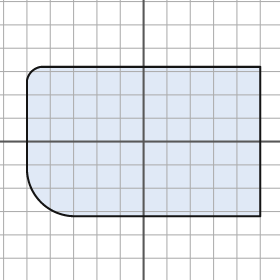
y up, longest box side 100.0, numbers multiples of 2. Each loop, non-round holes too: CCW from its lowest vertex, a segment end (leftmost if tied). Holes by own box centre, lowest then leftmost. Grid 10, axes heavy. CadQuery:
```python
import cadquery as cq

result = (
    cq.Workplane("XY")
    .moveTo(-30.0, -32.0)
    .lineTo(50.0, -32.0)
    .lineTo(50.0, 32.0)
    .lineTo(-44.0, 32.0)
    .threePointArc((-48.0, 30.0), (-50.0, 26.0))
    .lineTo(-50.0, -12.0)
    .threePointArc((-44.0, -26.0), (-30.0, -32.0))
    .close()
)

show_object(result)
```